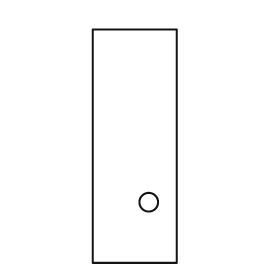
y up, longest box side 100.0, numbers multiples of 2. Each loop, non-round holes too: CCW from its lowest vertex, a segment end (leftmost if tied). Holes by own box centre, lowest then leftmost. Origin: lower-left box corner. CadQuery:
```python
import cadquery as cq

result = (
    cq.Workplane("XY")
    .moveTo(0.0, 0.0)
    .lineTo(36.0, 0.0)
    .lineTo(36.0, 100.0)
    .lineTo(0.0, 100.0)
    .close()
    .moveTo(24.0, 26.0)
    .circle(4.0)
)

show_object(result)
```